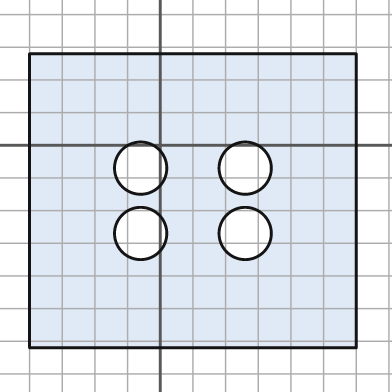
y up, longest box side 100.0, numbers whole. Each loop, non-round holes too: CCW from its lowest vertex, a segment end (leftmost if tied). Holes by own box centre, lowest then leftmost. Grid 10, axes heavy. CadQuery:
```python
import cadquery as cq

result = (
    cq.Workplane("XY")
    .moveTo(-40.0, -62.0)
    .lineTo(60.0, -62.0)
    .lineTo(60.0, 28.0)
    .lineTo(-40.0, 28.0)
    .close()
    .moveTo(-6.0, -27.0)
    .circle(8.0)
    .moveTo(26.0, -27.0)
    .circle(8.0)
    .moveTo(-6.0, -7.0)
    .circle(8.0)
    .moveTo(26.0, -7.0)
    .circle(8.0)
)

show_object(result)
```